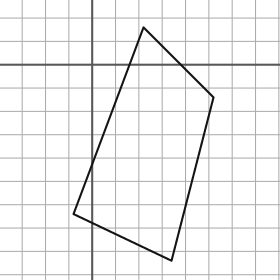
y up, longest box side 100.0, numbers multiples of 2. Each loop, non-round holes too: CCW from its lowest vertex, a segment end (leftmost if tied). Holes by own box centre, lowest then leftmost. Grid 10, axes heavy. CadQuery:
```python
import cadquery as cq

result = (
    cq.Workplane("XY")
    .moveTo(34.0, -84.0)
    .lineTo(52.0, -14.0)
    .lineTo(22.0, 16.0)
    .lineTo(-8.0, -64.0)
    .close()
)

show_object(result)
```